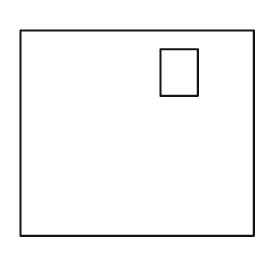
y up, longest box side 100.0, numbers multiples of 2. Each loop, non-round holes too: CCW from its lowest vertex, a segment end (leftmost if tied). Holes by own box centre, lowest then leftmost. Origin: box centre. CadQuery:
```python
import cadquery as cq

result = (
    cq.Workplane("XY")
    .moveTo(-50.0, -44.0)
    .lineTo(50.0, -44.0)
    .lineTo(50.0, 44.0)
    .lineTo(-50.0, 44.0)
    .close()
    .moveTo(10.0, 16.0)
    .lineTo(26.0, 16.0)
    .lineTo(26.0, 36.0)
    .lineTo(10.0, 36.0)
    .close()
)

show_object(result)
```